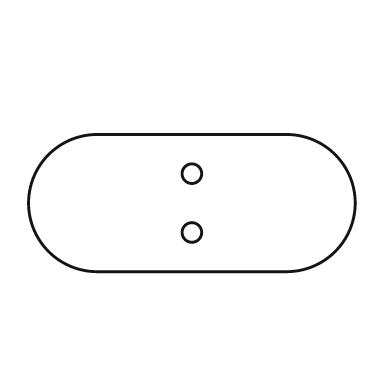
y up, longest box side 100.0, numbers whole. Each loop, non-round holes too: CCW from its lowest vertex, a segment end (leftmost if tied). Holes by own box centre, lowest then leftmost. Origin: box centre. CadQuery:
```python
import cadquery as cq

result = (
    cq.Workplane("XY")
    .moveTo(-29.0, -21.0)
    .lineTo(29.0, -21.0)
    .threePointArc((50.0, 0.0), (29.0, 21.0))
    .lineTo(-29.0, 21.0)
    .threePointArc((-50.0, 0.0), (-29.0, -21.0))
    .close()
    .moveTo(0.0, -9.0)
    .circle(3.0)
    .moveTo(0.0, 9.0)
    .circle(3.0)
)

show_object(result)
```